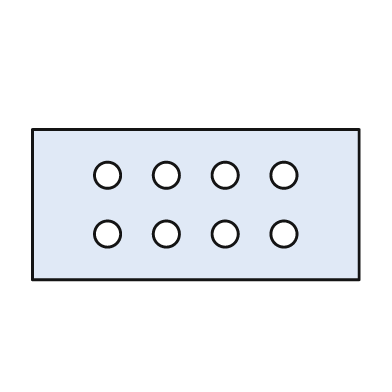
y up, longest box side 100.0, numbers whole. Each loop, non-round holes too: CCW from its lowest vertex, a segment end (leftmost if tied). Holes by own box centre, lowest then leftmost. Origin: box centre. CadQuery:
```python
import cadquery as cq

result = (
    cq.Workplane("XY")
    .moveTo(-50.0, -23.0)
    .lineTo(50.0, -23.0)
    .lineTo(50.0, 23.0)
    .lineTo(-50.0, 23.0)
    .close()
    .moveTo(-27.0, -9.0)
    .circle(4.0)
    .moveTo(-9.0, -9.0)
    .circle(4.0)
    .moveTo(9.0, -9.0)
    .circle(4.0)
    .moveTo(27.0, -9.0)
    .circle(4.0)
    .moveTo(-27.0, 9.0)
    .circle(4.0)
    .moveTo(-9.0, 9.0)
    .circle(4.0)
    .moveTo(9.0, 9.0)
    .circle(4.0)
    .moveTo(27.0, 9.0)
    .circle(4.0)
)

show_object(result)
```